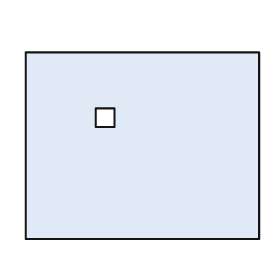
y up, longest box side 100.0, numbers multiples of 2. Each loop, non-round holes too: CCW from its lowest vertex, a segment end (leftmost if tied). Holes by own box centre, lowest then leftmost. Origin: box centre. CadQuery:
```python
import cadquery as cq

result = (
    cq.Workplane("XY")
    .moveTo(-50.0, -40.0)
    .lineTo(50.0, -40.0)
    .lineTo(50.0, 40.0)
    .lineTo(-50.0, 40.0)
    .close()
    .moveTo(-20.0, 8.0)
    .lineTo(-12.0, 8.0)
    .lineTo(-12.0, 16.0)
    .lineTo(-20.0, 16.0)
    .close()
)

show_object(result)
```